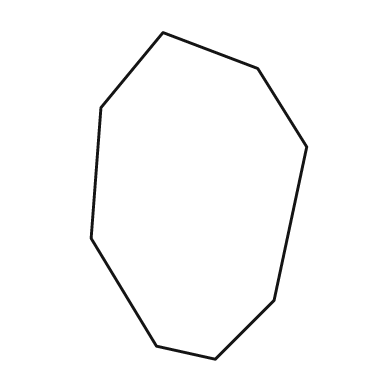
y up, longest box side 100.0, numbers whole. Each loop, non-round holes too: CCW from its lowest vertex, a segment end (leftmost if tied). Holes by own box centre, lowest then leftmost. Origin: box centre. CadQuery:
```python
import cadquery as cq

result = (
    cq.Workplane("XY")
    .moveTo(5.0, -50.0)
    .lineTo(23.0, -32.0)
    .lineTo(33.0, 15.0)
    .lineTo(18.0, 39.0)
    .lineTo(-11.0, 50.0)
    .lineTo(-30.0, 27.0)
    .lineTo(-33.0, -13.0)
    .lineTo(-13.0, -46.0)
    .close()
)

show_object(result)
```